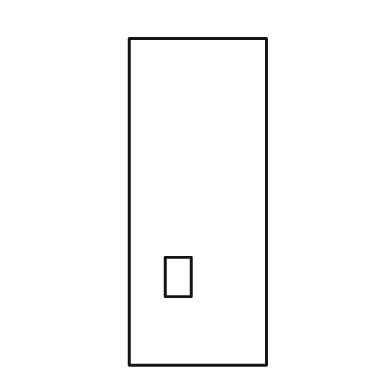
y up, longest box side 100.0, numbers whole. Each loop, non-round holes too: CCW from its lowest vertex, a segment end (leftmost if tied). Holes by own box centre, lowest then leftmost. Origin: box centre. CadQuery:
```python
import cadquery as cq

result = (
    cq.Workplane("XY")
    .moveTo(-21.0, -50.0)
    .lineTo(21.0, -50.0)
    .lineTo(21.0, 50.0)
    .lineTo(-21.0, 50.0)
    .close()
    .moveTo(-10.0, -29.0)
    .lineTo(-2.0, -29.0)
    .lineTo(-2.0, -17.0)
    .lineTo(-10.0, -17.0)
    .close()
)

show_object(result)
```